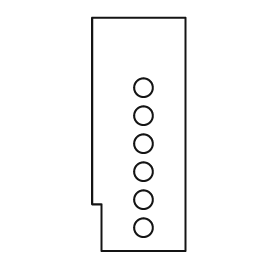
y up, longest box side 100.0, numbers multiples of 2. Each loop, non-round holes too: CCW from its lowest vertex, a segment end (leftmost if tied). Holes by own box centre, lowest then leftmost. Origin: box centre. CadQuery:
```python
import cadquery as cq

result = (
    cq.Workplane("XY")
    .moveTo(-16.0, -50.0)
    .lineTo(20.0, -50.0)
    .lineTo(20.0, 50.0)
    .lineTo(-20.0, 50.0)
    .lineTo(-20.0, -30.0)
    .lineTo(-16.0, -30.0)
    .close()
    .moveTo(2.0, -40.0)
    .circle(4.0)
    .moveTo(2.0, -28.0)
    .circle(4.0)
    .moveTo(2.0, -16.0)
    .circle(4.0)
    .moveTo(2.0, -4.0)
    .circle(4.0)
    .moveTo(2.0, 8.0)
    .circle(4.0)
    .moveTo(2.0, 20.0)
    .circle(4.0)
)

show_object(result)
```